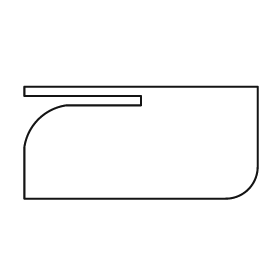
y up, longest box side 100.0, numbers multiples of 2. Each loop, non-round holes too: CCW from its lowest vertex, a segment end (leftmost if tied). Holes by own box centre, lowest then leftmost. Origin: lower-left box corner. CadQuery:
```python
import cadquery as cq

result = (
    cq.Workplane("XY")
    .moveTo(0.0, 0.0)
    .lineTo(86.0, 0.0)
    .threePointArc((96.0, 4.0), (100.0, 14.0))
    .lineTo(100.0, 48.0)
    .lineTo(0.0, 48.0)
    .lineTo(0.0, 44.0)
    .lineTo(50.0, 44.0)
    .lineTo(50.0, 40.0)
    .lineTo(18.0, 40.0)
    .threePointArc((6.0, 34.0), (0.0, 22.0))
    .close()
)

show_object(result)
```